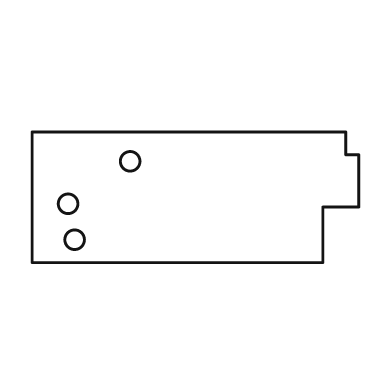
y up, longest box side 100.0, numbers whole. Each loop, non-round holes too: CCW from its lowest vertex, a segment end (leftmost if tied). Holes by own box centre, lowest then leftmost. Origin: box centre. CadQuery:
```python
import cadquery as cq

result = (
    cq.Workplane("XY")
    .moveTo(-50.0, -20.0)
    .lineTo(39.0, -20.0)
    .lineTo(39.0, -3.0)
    .lineTo(50.0, -3.0)
    .lineTo(50.0, 13.0)
    .lineTo(46.0, 13.0)
    .lineTo(46.0, 20.0)
    .lineTo(-50.0, 20.0)
    .close()
    .moveTo(-37.0, -13.0)
    .circle(3.0)
    .moveTo(-39.0, -2.0)
    .circle(3.0)
    .moveTo(-20.0, 11.0)
    .circle(3.0)
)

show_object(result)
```